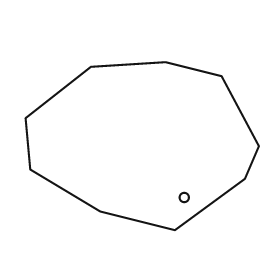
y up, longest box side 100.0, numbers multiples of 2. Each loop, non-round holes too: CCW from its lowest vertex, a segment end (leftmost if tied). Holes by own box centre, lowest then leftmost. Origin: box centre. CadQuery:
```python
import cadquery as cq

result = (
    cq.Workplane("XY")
    .moveTo(14.0, -36.0)
    .lineTo(44.0, -14.0)
    .lineTo(50.0, 0.0)
    .lineTo(34.0, 30.0)
    .lineTo(10.0, 36.0)
    .lineTo(-22.0, 34.0)
    .lineTo(-50.0, 12.0)
    .lineTo(-48.0, -10.0)
    .lineTo(-18.0, -28.0)
    .close()
    .moveTo(18.0, -22.0)
    .circle(2.0)
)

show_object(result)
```